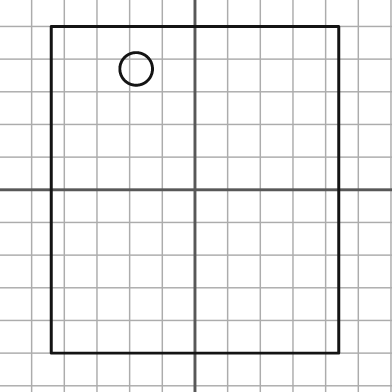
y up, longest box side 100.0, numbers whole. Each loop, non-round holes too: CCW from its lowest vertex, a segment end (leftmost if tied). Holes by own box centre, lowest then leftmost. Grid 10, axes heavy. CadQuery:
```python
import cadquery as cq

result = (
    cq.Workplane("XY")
    .moveTo(-44.0, -50.0)
    .lineTo(44.0, -50.0)
    .lineTo(44.0, 50.0)
    .lineTo(-44.0, 50.0)
    .close()
    .moveTo(-18.0, 37.0)
    .circle(5.0)
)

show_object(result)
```